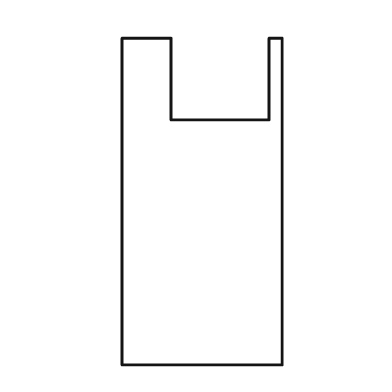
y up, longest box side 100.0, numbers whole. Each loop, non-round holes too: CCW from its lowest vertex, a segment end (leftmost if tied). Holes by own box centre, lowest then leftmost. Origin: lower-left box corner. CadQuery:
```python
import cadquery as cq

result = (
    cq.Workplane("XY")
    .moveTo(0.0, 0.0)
    .lineTo(49.0, 0.0)
    .lineTo(49.0, 100.0)
    .lineTo(45.0, 100.0)
    .lineTo(45.0, 75.0)
    .lineTo(15.0, 75.0)
    .lineTo(15.0, 100.0)
    .lineTo(0.0, 100.0)
    .close()
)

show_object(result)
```